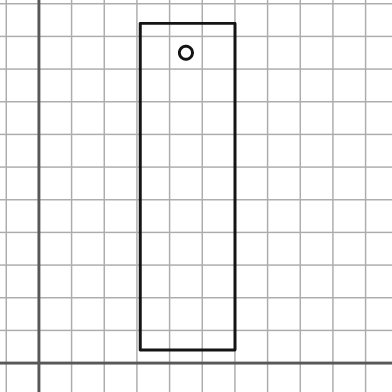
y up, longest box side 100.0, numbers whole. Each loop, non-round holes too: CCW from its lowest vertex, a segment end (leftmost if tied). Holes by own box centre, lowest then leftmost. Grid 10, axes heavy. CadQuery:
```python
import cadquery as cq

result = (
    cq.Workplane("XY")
    .moveTo(31.0, 4.0)
    .lineTo(60.0, 4.0)
    .lineTo(60.0, 104.0)
    .lineTo(31.0, 104.0)
    .close()
    .moveTo(45.0, 95.0)
    .circle(2.0)
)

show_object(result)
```